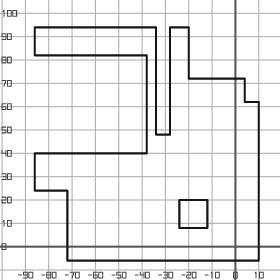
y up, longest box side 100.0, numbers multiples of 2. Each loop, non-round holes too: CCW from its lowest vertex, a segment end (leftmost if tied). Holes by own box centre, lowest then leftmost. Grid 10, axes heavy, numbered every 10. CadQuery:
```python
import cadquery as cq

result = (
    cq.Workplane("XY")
    .moveTo(-72.0, -6.0)
    .lineTo(10.0, -6.0)
    .lineTo(10.0, 62.0)
    .lineTo(4.0, 62.0)
    .lineTo(4.0, 72.0)
    .lineTo(-20.0, 72.0)
    .lineTo(-20.0, 94.0)
    .lineTo(-28.0, 94.0)
    .lineTo(-28.0, 48.0)
    .lineTo(-34.0, 48.0)
    .lineTo(-34.0, 94.0)
    .lineTo(-86.0, 94.0)
    .lineTo(-86.0, 82.0)
    .lineTo(-38.0, 82.0)
    .lineTo(-38.0, 40.0)
    .lineTo(-86.0, 40.0)
    .lineTo(-86.0, 24.0)
    .lineTo(-72.0, 24.0)
    .close()
    .moveTo(-24.0, 8.0)
    .lineTo(-12.0, 8.0)
    .lineTo(-12.0, 20.0)
    .lineTo(-24.0, 20.0)
    .close()
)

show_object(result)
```